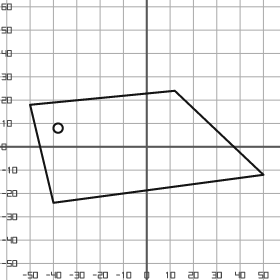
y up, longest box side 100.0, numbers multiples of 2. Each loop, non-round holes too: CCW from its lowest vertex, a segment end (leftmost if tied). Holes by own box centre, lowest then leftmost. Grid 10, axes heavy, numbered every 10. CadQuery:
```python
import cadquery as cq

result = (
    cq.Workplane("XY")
    .moveTo(-40.0, -24.0)
    .lineTo(50.0, -12.0)
    .lineTo(12.0, 24.0)
    .lineTo(-50.0, 18.0)
    .close()
    .moveTo(-38.0, 8.0)
    .circle(2.0)
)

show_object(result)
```